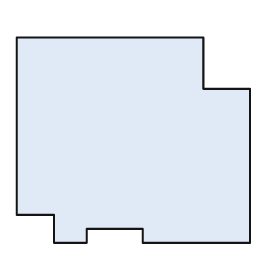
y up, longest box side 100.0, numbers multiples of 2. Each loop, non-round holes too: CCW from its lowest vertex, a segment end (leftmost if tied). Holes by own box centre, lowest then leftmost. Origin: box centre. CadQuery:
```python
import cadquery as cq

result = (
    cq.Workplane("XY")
    .moveTo(-34.0, -44.0)
    .lineTo(-20.0, -44.0)
    .lineTo(-20.0, -38.0)
    .lineTo(4.0, -38.0)
    .lineTo(4.0, -44.0)
    .lineTo(50.0, -44.0)
    .lineTo(50.0, 22.0)
    .lineTo(30.0, 22.0)
    .lineTo(30.0, 44.0)
    .lineTo(-50.0, 44.0)
    .lineTo(-50.0, -32.0)
    .lineTo(-34.0, -32.0)
    .close()
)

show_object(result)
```